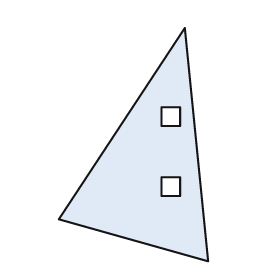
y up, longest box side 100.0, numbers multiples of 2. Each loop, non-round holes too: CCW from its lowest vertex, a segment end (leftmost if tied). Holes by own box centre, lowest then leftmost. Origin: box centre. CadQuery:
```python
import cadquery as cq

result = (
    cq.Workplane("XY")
    .moveTo(32.0, -50.0)
    .lineTo(22.0, 50.0)
    .lineTo(-32.0, -32.0)
    .close()
    .moveTo(12.0, -22.0)
    .lineTo(20.0, -22.0)
    .lineTo(20.0, -14.0)
    .lineTo(12.0, -14.0)
    .close()
    .moveTo(12.0, 8.0)
    .lineTo(20.0, 8.0)
    .lineTo(20.0, 16.0)
    .lineTo(12.0, 16.0)
    .close()
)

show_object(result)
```